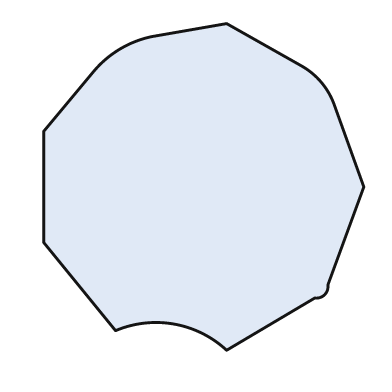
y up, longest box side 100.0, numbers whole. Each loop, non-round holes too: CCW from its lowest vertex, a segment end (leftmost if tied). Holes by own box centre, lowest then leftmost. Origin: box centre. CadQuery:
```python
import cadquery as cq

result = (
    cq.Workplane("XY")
    .moveTo(7.0, -50.0)
    .lineTo(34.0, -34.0)
    .threePointArc((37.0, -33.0), (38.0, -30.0))
    .lineTo(49.0, 0.0)
    .lineTo(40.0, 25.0)
    .threePointArc((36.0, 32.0), (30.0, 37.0))
    .lineTo(7.0, 50.0)
    .lineTo(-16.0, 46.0)
    .threePointArc((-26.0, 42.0), (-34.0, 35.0))
    .lineTo(-49.0, 17.0)
    .lineTo(-49.0, -17.0)
    .lineTo(-27.0, -44.0)
    .threePointArc((-9.0, -42.0), (7.0, -50.0))
    .close()
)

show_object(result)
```